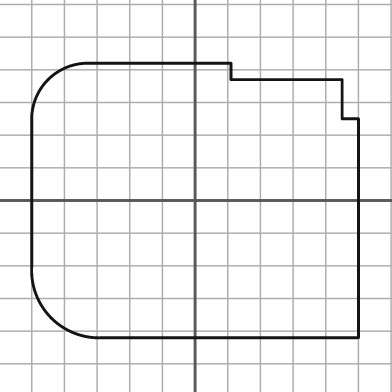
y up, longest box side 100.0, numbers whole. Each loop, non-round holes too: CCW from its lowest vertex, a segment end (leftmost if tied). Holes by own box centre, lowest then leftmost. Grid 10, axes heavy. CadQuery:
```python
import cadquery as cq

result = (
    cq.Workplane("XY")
    .moveTo(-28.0, -42.0)
    .lineTo(50.0, -42.0)
    .lineTo(50.0, 25.0)
    .lineTo(45.0, 25.0)
    .lineTo(45.0, 37.0)
    .lineTo(11.0, 37.0)
    .lineTo(11.0, 42.0)
    .lineTo(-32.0, 42.0)
    .threePointArc((-45.0, 37.0), (-50.0, 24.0))
    .lineTo(-50.0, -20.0)
    .threePointArc((-44.0, -36.0), (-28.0, -42.0))
    .close()
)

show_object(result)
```